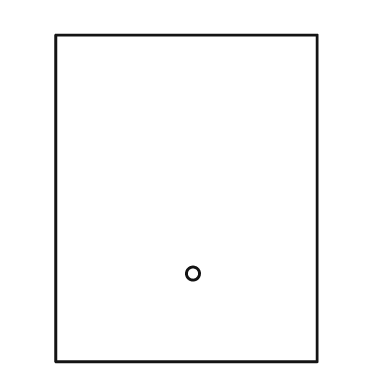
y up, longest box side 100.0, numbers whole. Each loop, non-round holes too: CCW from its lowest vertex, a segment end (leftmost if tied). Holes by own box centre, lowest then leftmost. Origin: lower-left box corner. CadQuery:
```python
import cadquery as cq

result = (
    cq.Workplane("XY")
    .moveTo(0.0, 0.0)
    .lineTo(80.0, 0.0)
    .lineTo(80.0, 100.0)
    .lineTo(0.0, 100.0)
    .close()
    .moveTo(42.0, 27.0)
    .circle(2.0)
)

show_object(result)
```